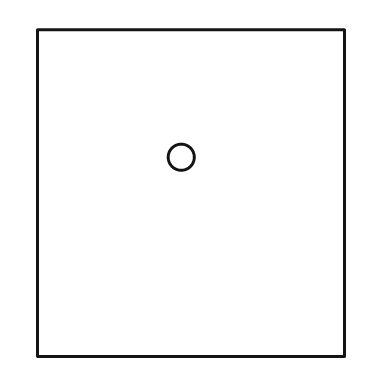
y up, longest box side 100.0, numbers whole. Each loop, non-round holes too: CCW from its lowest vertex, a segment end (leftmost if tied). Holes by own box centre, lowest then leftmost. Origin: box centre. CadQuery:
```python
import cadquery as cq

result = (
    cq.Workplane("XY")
    .moveTo(-47.0, -50.0)
    .lineTo(47.0, -50.0)
    .lineTo(47.0, 50.0)
    .lineTo(-47.0, 50.0)
    .close()
    .moveTo(-3.0, 11.0)
    .circle(4.0)
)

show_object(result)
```